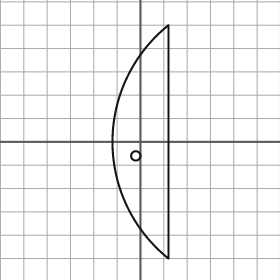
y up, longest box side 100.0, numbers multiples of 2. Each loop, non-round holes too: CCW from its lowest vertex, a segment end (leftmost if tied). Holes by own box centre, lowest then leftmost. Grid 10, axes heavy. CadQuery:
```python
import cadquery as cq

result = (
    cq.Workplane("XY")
    .moveTo(12.0, -50.0)
    .lineTo(12.0, 50.0)
    .threePointArc((-12.0, 0.0), (12.0, -50.0))
    .close()
    .moveTo(-2.0, -6.0)
    .circle(2.0)
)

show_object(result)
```